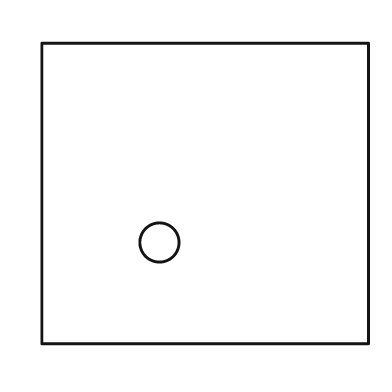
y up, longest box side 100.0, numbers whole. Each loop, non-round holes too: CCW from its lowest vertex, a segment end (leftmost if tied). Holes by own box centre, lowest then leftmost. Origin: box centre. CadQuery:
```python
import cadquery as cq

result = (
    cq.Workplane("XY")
    .moveTo(-50.0, -46.0)
    .lineTo(50.0, -46.0)
    .lineTo(50.0, 46.0)
    .lineTo(-50.0, 46.0)
    .close()
    .moveTo(-14.0, -15.0)
    .circle(6.0)
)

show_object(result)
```